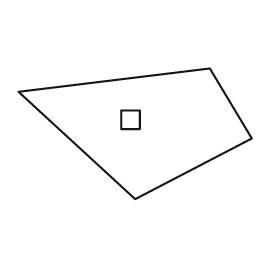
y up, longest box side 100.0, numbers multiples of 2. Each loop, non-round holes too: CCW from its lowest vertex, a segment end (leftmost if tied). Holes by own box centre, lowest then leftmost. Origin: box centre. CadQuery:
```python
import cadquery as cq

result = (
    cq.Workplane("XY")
    .moveTo(0.0, -28.0)
    .lineTo(50.0, -2.0)
    .lineTo(32.0, 28.0)
    .lineTo(-50.0, 18.0)
    .close()
    .moveTo(-6.0, 2.0)
    .lineTo(2.0, 2.0)
    .lineTo(2.0, 10.0)
    .lineTo(-6.0, 10.0)
    .close()
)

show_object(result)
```